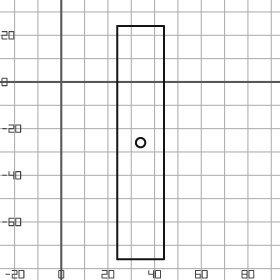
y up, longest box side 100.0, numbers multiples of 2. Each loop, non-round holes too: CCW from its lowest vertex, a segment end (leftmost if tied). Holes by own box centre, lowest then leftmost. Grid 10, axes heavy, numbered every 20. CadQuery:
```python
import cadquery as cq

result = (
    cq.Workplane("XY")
    .moveTo(24.0, -76.0)
    .lineTo(44.0, -76.0)
    .lineTo(44.0, 24.0)
    .lineTo(24.0, 24.0)
    .close()
    .moveTo(34.0, -26.0)
    .circle(2.0)
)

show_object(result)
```